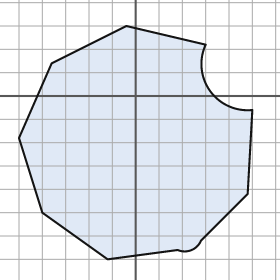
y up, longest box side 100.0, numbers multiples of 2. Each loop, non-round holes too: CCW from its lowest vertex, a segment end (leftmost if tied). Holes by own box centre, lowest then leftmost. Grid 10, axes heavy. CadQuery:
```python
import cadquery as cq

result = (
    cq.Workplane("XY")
    .moveTo(-12.0, -70.0)
    .lineTo(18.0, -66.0)
    .threePointArc((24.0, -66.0), (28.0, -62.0))
    .lineTo(48.0, -42.0)
    .lineTo(50.0, -6.0)
    .threePointArc((32.0, 2.0), (30.0, 22.0))
    .lineTo(-4.0, 30.0)
    .lineTo(-36.0, 14.0)
    .lineTo(-50.0, -18.0)
    .lineTo(-40.0, -50.0)
    .close()
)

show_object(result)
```